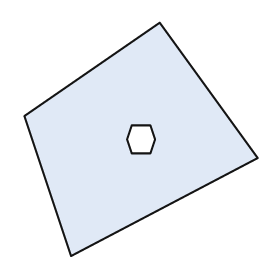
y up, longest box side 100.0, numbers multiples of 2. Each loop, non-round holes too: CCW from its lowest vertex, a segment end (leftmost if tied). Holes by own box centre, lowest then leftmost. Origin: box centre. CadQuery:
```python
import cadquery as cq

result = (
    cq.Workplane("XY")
    .moveTo(-30.0, -50.0)
    .lineTo(50.0, -8.0)
    .lineTo(8.0, 50.0)
    .lineTo(-50.0, 10.0)
    .close()
    .moveTo(-4.0, -6.0)
    .lineTo(4.0, -6.0)
    .lineTo(6.0, 0.0)
    .lineTo(4.0, 6.0)
    .lineTo(-4.0, 6.0)
    .lineTo(-6.0, 0.0)
    .close()
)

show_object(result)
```